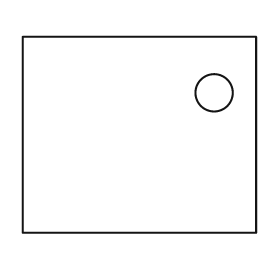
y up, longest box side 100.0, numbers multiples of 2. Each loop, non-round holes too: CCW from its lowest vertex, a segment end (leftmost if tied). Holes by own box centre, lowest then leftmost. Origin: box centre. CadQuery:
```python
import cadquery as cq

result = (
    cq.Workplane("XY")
    .moveTo(-50.0, -42.0)
    .lineTo(50.0, -42.0)
    .lineTo(50.0, 42.0)
    .lineTo(-50.0, 42.0)
    .close()
    .moveTo(32.0, 18.0)
    .circle(8.0)
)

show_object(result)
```